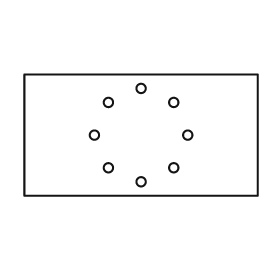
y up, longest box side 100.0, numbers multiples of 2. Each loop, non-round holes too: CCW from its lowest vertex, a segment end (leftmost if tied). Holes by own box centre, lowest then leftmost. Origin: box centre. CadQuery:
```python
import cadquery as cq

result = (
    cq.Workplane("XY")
    .moveTo(-50.0, -26.0)
    .lineTo(50.0, -26.0)
    .lineTo(50.0, 26.0)
    .lineTo(-50.0, 26.0)
    .close()
    .moveTo(0.0, -20.0)
    .circle(2.0)
    .moveTo(-14.0, -14.0)
    .circle(2.0)
    .moveTo(14.0, -14.0)
    .circle(2.0)
    .moveTo(-20.0, 0.0)
    .circle(2.0)
    .moveTo(20.0, 0.0)
    .circle(2.0)
    .moveTo(-14.0, 14.0)
    .circle(2.0)
    .moveTo(14.0, 14.0)
    .circle(2.0)
    .moveTo(0.0, 20.0)
    .circle(2.0)
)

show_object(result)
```